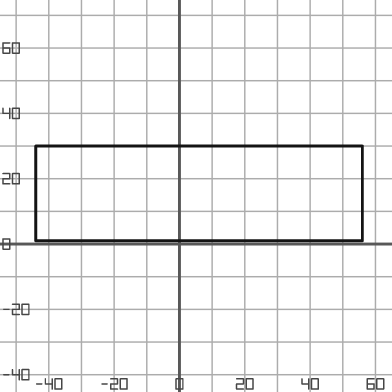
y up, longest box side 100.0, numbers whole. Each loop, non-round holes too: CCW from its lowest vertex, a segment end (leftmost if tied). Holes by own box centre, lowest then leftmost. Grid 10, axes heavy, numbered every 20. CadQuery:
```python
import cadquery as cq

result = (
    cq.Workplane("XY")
    .moveTo(-44.0, 1.0)
    .lineTo(56.0, 1.0)
    .lineTo(56.0, 30.0)
    .lineTo(-44.0, 30.0)
    .close()
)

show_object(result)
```